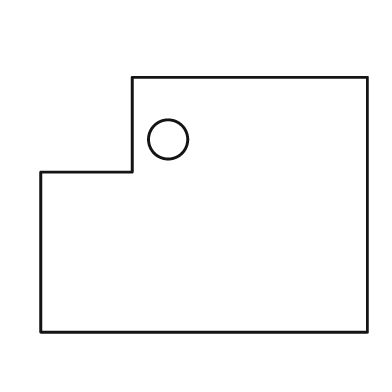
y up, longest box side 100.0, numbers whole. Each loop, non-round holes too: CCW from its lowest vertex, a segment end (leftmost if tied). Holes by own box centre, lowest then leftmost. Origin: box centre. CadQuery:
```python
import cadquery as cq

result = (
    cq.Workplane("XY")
    .moveTo(-50.0, -39.0)
    .lineTo(50.0, -39.0)
    .lineTo(50.0, 39.0)
    .lineTo(-22.0, 39.0)
    .lineTo(-22.0, 10.0)
    .lineTo(-50.0, 10.0)
    .close()
    .moveTo(-11.0, 20.0)
    .circle(6.0)
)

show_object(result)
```